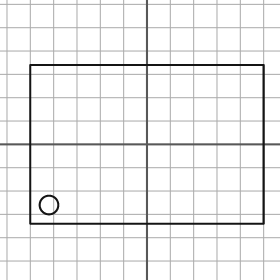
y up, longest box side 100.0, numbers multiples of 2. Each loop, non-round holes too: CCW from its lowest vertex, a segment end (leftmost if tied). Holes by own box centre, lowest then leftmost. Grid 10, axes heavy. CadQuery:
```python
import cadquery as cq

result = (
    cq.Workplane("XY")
    .moveTo(-50.0, -34.0)
    .lineTo(50.0, -34.0)
    .lineTo(50.0, 34.0)
    .lineTo(-50.0, 34.0)
    .close()
    .moveTo(-42.0, -26.0)
    .circle(4.0)
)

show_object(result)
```